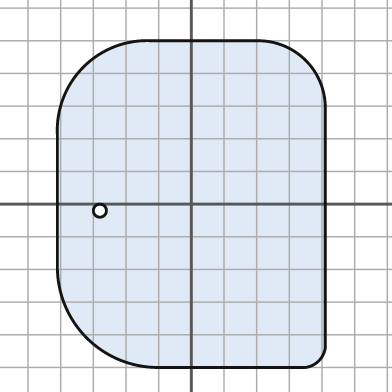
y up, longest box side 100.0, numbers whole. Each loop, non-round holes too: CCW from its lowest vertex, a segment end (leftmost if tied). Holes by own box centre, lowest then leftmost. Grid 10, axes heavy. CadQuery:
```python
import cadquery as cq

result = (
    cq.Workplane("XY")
    .moveTo(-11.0, -50.0)
    .lineTo(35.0, -50.0)
    .threePointArc((39.0, -48.0), (41.0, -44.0))
    .lineTo(41.0, 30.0)
    .threePointArc((35.0, 44.0), (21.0, 50.0))
    .lineTo(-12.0, 50.0)
    .threePointArc((-33.0, 42.0), (-41.0, 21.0))
    .lineTo(-41.0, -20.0)
    .threePointArc((-32.0, -41.0), (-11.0, -50.0))
    .close()
    .moveTo(-28.0, -2.0)
    .circle(2.0)
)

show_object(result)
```